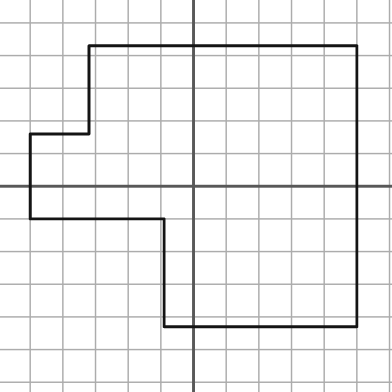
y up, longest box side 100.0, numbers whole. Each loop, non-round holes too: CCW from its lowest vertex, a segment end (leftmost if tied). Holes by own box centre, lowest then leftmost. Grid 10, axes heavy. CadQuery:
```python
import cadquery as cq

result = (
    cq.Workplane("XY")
    .moveTo(-9.0, -43.0)
    .lineTo(50.0, -43.0)
    .lineTo(50.0, 43.0)
    .lineTo(-32.0, 43.0)
    .lineTo(-32.0, 16.0)
    .lineTo(-50.0, 16.0)
    .lineTo(-50.0, -10.0)
    .lineTo(-9.0, -10.0)
    .close()
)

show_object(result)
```